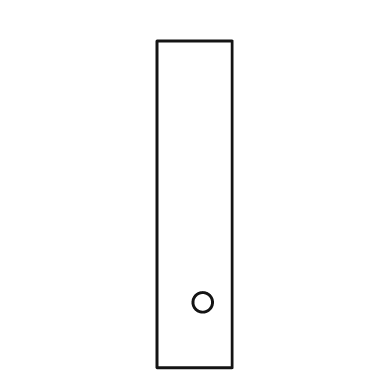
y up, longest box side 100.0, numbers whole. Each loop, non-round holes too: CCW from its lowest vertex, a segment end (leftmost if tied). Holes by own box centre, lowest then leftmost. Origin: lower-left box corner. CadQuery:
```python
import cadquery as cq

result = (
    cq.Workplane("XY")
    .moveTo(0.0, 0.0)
    .lineTo(23.0, 0.0)
    .lineTo(23.0, 100.0)
    .lineTo(0.0, 100.0)
    .close()
    .moveTo(14.0, 20.0)
    .circle(3.0)
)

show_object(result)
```